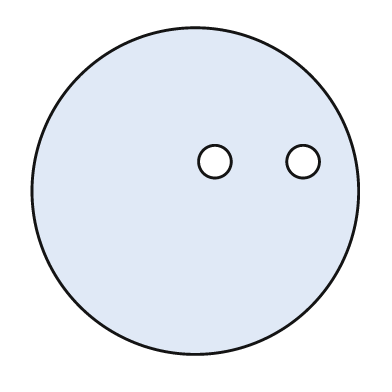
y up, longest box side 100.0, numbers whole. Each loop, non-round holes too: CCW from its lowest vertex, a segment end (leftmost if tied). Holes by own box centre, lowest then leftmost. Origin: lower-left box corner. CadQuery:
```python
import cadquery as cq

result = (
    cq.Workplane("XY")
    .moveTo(50.0, 50.0)
    .circle(50.0)
    .moveTo(56.0, 59.0)
    .circle(5.0)
    .moveTo(83.0, 59.0)
    .circle(5.0)
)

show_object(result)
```